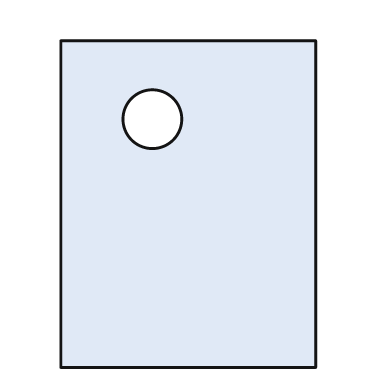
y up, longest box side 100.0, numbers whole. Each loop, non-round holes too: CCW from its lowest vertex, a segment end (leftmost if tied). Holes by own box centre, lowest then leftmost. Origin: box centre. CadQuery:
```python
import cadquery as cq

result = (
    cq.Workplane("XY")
    .moveTo(-39.0, -50.0)
    .lineTo(39.0, -50.0)
    .lineTo(39.0, 50.0)
    .lineTo(-39.0, 50.0)
    .close()
    .moveTo(-11.0, 26.0)
    .circle(9.0)
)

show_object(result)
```